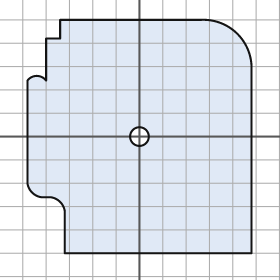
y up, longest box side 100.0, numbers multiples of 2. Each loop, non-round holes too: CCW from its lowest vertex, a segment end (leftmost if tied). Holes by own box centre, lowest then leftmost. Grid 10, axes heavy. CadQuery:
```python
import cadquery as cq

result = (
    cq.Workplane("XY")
    .moveTo(-32.0, -50.0)
    .lineTo(48.0, -50.0)
    .lineTo(48.0, 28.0)
    .threePointArc((42.0, 44.0), (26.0, 50.0))
    .lineTo(-34.0, 50.0)
    .lineTo(-34.0, 42.0)
    .lineTo(-40.0, 42.0)
    .lineTo(-40.0, 24.0)
    .threePointArc((-44.0, 26.0), (-48.0, 24.0))
    .lineTo(-48.0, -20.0)
    .threePointArc((-46.0, -24.0), (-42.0, -26.0))
    .lineTo(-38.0, -26.0)
    .threePointArc((-34.0, -28.0), (-32.0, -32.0))
    .close()
    .moveTo(0.0, 0.0)
    .circle(4.0)
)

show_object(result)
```